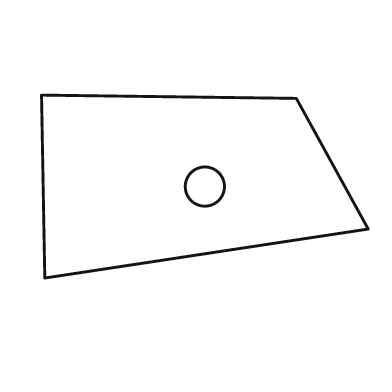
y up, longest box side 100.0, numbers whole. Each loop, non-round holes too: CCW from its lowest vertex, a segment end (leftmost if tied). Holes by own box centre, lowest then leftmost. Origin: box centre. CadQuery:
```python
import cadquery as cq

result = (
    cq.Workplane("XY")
    .moveTo(-49.0, -28.0)
    .lineTo(50.0, -13.0)
    .lineTo(28.0, 27.0)
    .lineTo(-50.0, 28.0)
    .close()
    .moveTo(0.0, 0.0)
    .circle(6.0)
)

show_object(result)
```